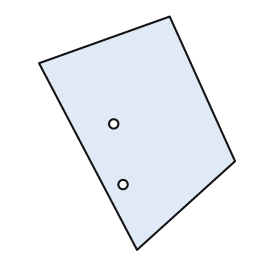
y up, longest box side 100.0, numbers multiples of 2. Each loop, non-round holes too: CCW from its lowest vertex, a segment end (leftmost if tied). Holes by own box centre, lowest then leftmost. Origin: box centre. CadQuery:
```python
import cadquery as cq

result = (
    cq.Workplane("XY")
    .moveTo(0.0, -50.0)
    .lineTo(42.0, -12.0)
    .lineTo(14.0, 50.0)
    .lineTo(-42.0, 30.0)
    .close()
    .moveTo(-6.0, -22.0)
    .circle(2.0)
    .moveTo(-10.0, 4.0)
    .circle(2.0)
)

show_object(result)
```